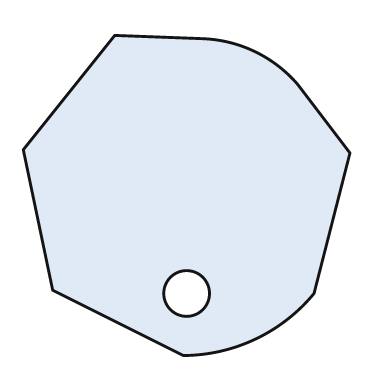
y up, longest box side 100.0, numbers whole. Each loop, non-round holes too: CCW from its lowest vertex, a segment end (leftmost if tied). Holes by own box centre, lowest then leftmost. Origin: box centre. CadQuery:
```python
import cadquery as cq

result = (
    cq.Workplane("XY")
    .moveTo(-1.0, -49.0)
    .threePointArc((21.0, -44.0), (39.0, -30.0))
    .lineTo(50.0, 13.0)
    .lineTo(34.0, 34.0)
    .threePointArc((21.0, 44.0), (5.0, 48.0))
    .lineTo(-22.0, 49.0)
    .lineTo(-50.0, 14.0)
    .lineTo(-41.0, -29.0)
    .close()
    .moveTo(0.0, -30.0)
    .circle(7.0)
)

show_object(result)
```